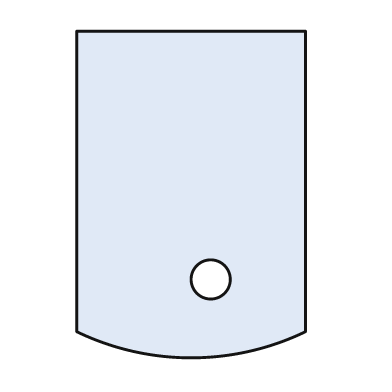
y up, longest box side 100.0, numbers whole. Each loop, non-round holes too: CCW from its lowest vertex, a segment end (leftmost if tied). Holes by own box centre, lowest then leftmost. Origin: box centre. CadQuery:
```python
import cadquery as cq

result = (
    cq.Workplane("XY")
    .moveTo(-35.0, -42.0)
    .threePointArc((0.0, -50.0), (35.0, -42.0))
    .lineTo(35.0, 50.0)
    .lineTo(-35.0, 50.0)
    .close()
    .moveTo(6.0, -26.0)
    .circle(6.0)
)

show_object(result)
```